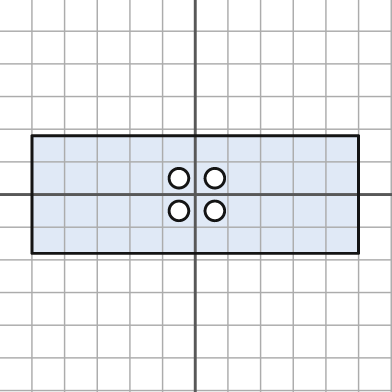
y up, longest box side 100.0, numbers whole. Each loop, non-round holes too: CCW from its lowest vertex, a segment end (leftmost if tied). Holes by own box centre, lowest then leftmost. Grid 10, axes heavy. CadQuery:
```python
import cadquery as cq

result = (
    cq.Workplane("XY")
    .moveTo(-50.0, -18.0)
    .lineTo(50.0, -18.0)
    .lineTo(50.0, 18.0)
    .lineTo(-50.0, 18.0)
    .close()
    .moveTo(-5.0, -5.0)
    .circle(3.0)
    .moveTo(6.0, -5.0)
    .circle(3.0)
    .moveTo(-5.0, 5.0)
    .circle(3.0)
    .moveTo(6.0, 5.0)
    .circle(3.0)
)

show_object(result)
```